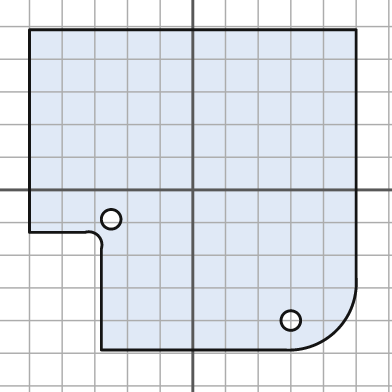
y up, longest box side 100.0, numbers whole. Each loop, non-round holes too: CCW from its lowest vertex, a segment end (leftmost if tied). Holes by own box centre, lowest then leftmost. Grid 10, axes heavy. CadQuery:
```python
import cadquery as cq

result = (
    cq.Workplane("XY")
    .moveTo(-28.0, -49.0)
    .lineTo(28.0, -49.0)
    .threePointArc((44.0, -43.0), (50.0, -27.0))
    .lineTo(50.0, 49.0)
    .lineTo(-50.0, 49.0)
    .lineTo(-50.0, -13.0)
    .lineTo(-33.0, -13.0)
    .threePointArc((-29.0, -14.0), (-28.0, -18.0))
    .close()
    .moveTo(30.0, -40.0)
    .circle(3.0)
    .moveTo(-25.0, -9.0)
    .circle(3.0)
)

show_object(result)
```